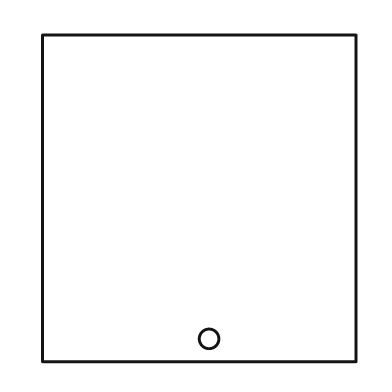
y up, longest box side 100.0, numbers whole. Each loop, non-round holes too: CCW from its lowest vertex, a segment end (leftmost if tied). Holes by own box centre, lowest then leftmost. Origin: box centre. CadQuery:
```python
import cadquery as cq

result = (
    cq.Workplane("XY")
    .moveTo(-48.0, -50.0)
    .lineTo(48.0, -50.0)
    .lineTo(48.0, 50.0)
    .lineTo(-48.0, 50.0)
    .close()
    .moveTo(3.0, -43.0)
    .circle(3.0)
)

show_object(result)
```